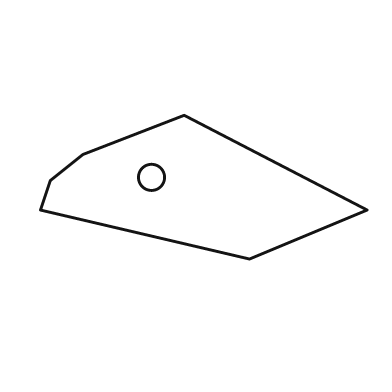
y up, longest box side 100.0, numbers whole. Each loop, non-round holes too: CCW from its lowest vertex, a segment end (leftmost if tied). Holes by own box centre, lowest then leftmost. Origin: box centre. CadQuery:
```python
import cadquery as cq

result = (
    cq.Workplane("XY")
    .moveTo(14.0, -22.0)
    .lineTo(50.0, -7.0)
    .lineTo(-6.0, 22.0)
    .lineTo(-37.0, 10.0)
    .lineTo(-47.0, 2.0)
    .lineTo(-50.0, -7.0)
    .close()
    .moveTo(-16.0, 3.0)
    .circle(4.0)
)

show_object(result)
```